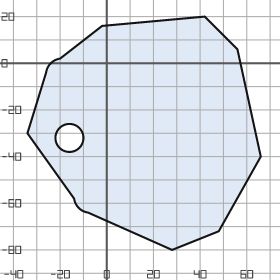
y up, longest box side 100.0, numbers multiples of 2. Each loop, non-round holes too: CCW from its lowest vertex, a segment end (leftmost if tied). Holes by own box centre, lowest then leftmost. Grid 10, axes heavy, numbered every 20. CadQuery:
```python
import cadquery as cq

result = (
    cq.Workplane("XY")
    .moveTo(28.0, -80.0)
    .lineTo(48.0, -72.0)
    .lineTo(66.0, -40.0)
    .lineTo(56.0, 6.0)
    .lineTo(42.0, 20.0)
    .lineTo(-2.0, 16.0)
    .lineTo(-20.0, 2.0)
    .threePointArc((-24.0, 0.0), (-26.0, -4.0))
    .lineTo(-34.0, -30.0)
    .lineTo(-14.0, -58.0)
    .threePointArc((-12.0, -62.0), (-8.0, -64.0))
    .close()
    .moveTo(-16.0, -32.0)
    .circle(6.0)
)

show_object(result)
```